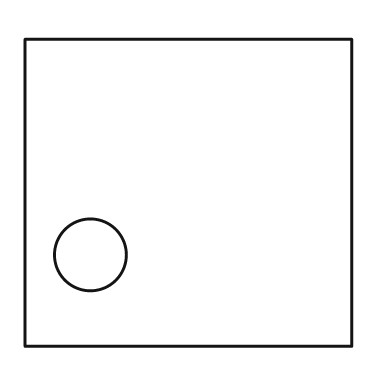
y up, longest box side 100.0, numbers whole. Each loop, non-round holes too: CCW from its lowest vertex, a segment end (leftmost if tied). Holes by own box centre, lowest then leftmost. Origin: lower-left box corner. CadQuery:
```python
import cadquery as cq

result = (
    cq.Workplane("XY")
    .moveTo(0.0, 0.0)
    .lineTo(100.0, 0.0)
    .lineTo(100.0, 94.0)
    .lineTo(0.0, 94.0)
    .close()
    .moveTo(20.0, 28.0)
    .circle(11.0)
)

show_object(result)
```